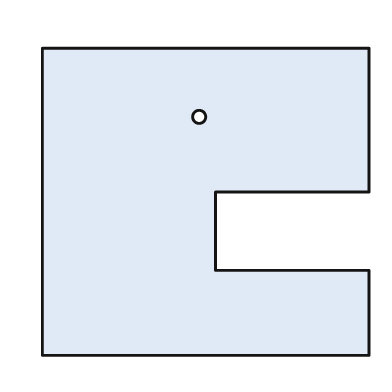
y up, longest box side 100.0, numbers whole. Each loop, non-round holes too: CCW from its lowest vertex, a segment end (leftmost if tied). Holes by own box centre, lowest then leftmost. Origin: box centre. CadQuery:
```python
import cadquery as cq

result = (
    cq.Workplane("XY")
    .moveTo(-50.0, -47.0)
    .lineTo(50.0, -47.0)
    .lineTo(50.0, -21.0)
    .lineTo(3.0, -21.0)
    .lineTo(3.0, 3.0)
    .lineTo(50.0, 3.0)
    .lineTo(50.0, 47.0)
    .lineTo(-50.0, 47.0)
    .close()
    .moveTo(-2.0, 26.0)
    .circle(2.0)
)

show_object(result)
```